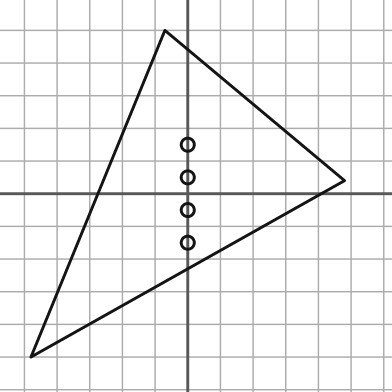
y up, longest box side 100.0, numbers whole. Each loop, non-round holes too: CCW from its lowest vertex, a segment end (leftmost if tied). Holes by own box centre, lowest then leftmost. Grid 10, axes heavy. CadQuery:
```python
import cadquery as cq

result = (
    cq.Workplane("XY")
    .moveTo(-48.0, -50.0)
    .lineTo(48.0, 4.0)
    .lineTo(-7.0, 50.0)
    .close()
    .moveTo(0.0, -15.0)
    .circle(2.0)
    .moveTo(0.0, -5.0)
    .circle(2.0)
    .moveTo(0.0, 5.0)
    .circle(2.0)
    .moveTo(0.0, 15.0)
    .circle(2.0)
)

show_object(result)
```